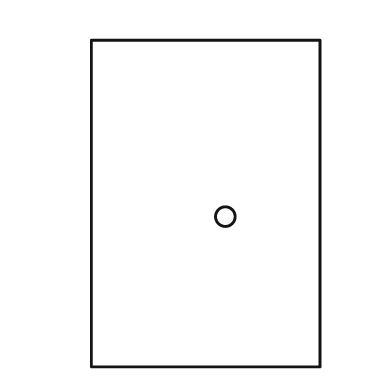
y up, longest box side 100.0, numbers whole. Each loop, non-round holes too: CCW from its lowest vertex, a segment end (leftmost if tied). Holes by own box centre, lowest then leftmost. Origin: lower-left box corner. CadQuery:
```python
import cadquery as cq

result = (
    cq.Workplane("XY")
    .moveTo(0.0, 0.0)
    .lineTo(70.0, 0.0)
    .lineTo(70.0, 100.0)
    .lineTo(0.0, 100.0)
    .close()
    .moveTo(41.0, 46.0)
    .circle(3.0)
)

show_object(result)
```